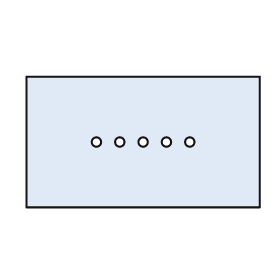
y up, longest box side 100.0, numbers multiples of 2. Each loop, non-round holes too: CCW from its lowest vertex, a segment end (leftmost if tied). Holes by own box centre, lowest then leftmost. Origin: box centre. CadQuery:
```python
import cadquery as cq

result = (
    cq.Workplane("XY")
    .moveTo(-50.0, -28.0)
    .lineTo(50.0, -28.0)
    .lineTo(50.0, 28.0)
    .lineTo(-50.0, 28.0)
    .close()
    .moveTo(-20.0, 0.0)
    .circle(2.0)
    .moveTo(-10.0, 0.0)
    .circle(2.0)
    .moveTo(0.0, 0.0)
    .circle(2.0)
    .moveTo(10.0, 0.0)
    .circle(2.0)
    .moveTo(20.0, 0.0)
    .circle(2.0)
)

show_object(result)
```